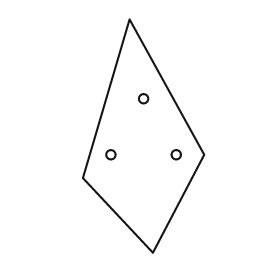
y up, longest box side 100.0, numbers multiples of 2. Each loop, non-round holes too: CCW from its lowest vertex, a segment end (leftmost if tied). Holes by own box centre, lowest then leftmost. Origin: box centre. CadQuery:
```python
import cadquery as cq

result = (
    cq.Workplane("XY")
    .moveTo(4.0, -50.0)
    .lineTo(26.0, -8.0)
    .lineTo(-6.0, 50.0)
    .lineTo(-26.0, -18.0)
    .close()
    .moveTo(-14.0, -8.0)
    .circle(2.0)
    .moveTo(14.0, -8.0)
    .circle(2.0)
    .moveTo(0.0, 16.0)
    .circle(2.0)
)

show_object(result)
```